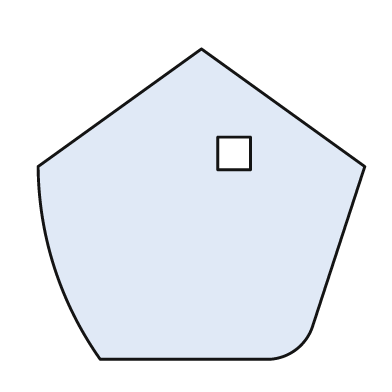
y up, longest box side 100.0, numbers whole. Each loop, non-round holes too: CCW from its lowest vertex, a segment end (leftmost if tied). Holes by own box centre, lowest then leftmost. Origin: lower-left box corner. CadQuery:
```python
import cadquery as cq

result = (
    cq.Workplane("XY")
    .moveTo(19.0, 0.0)
    .lineTo(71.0, 0.0)
    .threePointArc((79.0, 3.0), (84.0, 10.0))
    .lineTo(100.0, 59.0)
    .lineTo(50.0, 95.0)
    .lineTo(0.0, 59.0)
    .threePointArc((5.0, 28.0), (19.0, 0.0))
    .close()
    .moveTo(55.0, 58.0)
    .lineTo(65.0, 58.0)
    .lineTo(65.0, 68.0)
    .lineTo(55.0, 68.0)
    .close()
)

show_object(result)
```